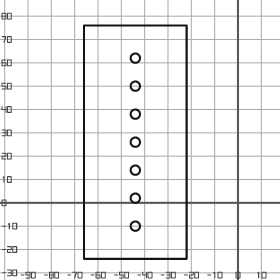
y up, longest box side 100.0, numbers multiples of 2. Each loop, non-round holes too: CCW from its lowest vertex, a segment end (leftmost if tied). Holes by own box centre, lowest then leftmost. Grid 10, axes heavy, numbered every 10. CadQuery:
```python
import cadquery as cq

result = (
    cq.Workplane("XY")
    .moveTo(-66.0, -24.0)
    .lineTo(-22.0, -24.0)
    .lineTo(-22.0, 76.0)
    .lineTo(-66.0, 76.0)
    .close()
    .moveTo(-44.0, -10.0)
    .circle(2.0)
    .moveTo(-44.0, 2.0)
    .circle(2.0)
    .moveTo(-44.0, 14.0)
    .circle(2.0)
    .moveTo(-44.0, 26.0)
    .circle(2.0)
    .moveTo(-44.0, 38.0)
    .circle(2.0)
    .moveTo(-44.0, 50.0)
    .circle(2.0)
    .moveTo(-44.0, 62.0)
    .circle(2.0)
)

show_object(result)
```